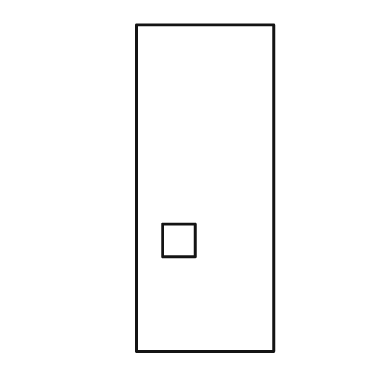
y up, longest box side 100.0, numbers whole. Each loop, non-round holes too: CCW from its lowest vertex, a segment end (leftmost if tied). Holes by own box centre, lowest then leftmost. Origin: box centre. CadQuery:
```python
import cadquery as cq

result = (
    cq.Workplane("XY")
    .moveTo(-21.0, -50.0)
    .lineTo(21.0, -50.0)
    .lineTo(21.0, 50.0)
    .lineTo(-21.0, 50.0)
    .close()
    .moveTo(-13.0, -21.0)
    .lineTo(-3.0, -21.0)
    .lineTo(-3.0, -11.0)
    .lineTo(-13.0, -11.0)
    .close()
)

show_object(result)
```